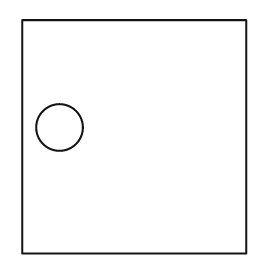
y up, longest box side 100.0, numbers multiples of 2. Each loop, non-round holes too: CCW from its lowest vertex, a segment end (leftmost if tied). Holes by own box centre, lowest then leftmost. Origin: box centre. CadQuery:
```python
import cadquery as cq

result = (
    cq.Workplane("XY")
    .moveTo(-48.0, -50.0)
    .lineTo(48.0, -50.0)
    .lineTo(48.0, 50.0)
    .lineTo(-48.0, 50.0)
    .close()
    .moveTo(-32.0, 4.0)
    .circle(10.0)
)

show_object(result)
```